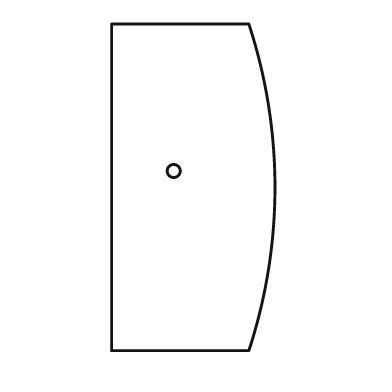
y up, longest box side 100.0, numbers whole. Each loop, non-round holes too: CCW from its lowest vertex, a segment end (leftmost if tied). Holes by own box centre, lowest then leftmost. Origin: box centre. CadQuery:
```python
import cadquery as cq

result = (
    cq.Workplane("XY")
    .moveTo(-25.0, -50.0)
    .lineTo(17.0, -50.0)
    .threePointArc((25.0, 0.0), (17.0, 50.0))
    .lineTo(-25.0, 50.0)
    .close()
    .moveTo(-6.0, 5.0)
    .circle(2.0)
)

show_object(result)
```